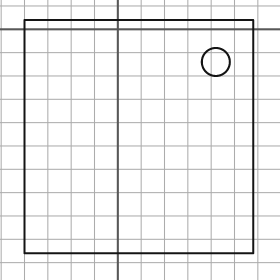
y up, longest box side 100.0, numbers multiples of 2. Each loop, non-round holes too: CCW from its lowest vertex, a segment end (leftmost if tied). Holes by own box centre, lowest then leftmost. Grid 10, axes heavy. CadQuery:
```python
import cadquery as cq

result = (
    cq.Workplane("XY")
    .moveTo(-40.0, -96.0)
    .lineTo(58.0, -96.0)
    .lineTo(58.0, 4.0)
    .lineTo(-40.0, 4.0)
    .close()
    .moveTo(42.0, -14.0)
    .circle(6.0)
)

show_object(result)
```